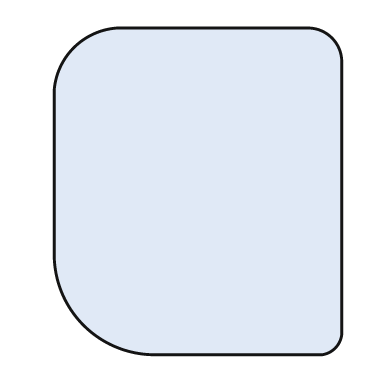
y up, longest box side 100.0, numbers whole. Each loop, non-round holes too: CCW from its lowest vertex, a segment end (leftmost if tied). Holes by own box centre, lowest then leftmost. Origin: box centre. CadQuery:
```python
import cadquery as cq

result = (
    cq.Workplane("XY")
    .moveTo(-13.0, -50.0)
    .lineTo(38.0, -50.0)
    .threePointArc((42.0, -48.0), (44.0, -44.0))
    .lineTo(44.0, 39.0)
    .threePointArc((41.0, 47.0), (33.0, 50.0))
    .lineTo(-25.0, 50.0)
    .threePointArc((-38.0, 44.0), (-44.0, 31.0))
    .lineTo(-44.0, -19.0)
    .threePointArc((-35.0, -41.0), (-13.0, -50.0))
    .close()
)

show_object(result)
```